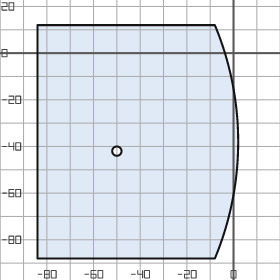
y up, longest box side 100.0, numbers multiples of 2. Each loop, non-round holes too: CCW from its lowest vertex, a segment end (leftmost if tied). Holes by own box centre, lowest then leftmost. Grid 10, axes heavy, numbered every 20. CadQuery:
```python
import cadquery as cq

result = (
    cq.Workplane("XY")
    .moveTo(-84.0, -88.0)
    .lineTo(-8.0, -88.0)
    .threePointArc((2.0, -38.0), (-8.0, 12.0))
    .lineTo(-84.0, 12.0)
    .close()
    .moveTo(-50.0, -42.0)
    .circle(2.0)
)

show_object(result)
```